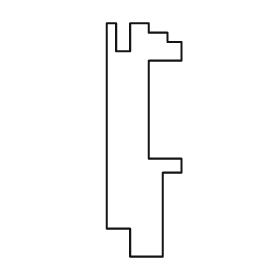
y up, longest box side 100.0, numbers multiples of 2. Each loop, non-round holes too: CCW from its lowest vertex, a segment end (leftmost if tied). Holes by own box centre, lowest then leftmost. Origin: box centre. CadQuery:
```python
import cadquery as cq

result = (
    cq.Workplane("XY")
    .moveTo(-6.0, -50.0)
    .lineTo(8.0, -50.0)
    .lineTo(8.0, -14.0)
    .lineTo(16.0, -14.0)
    .lineTo(16.0, -8.0)
    .lineTo(2.0, -8.0)
    .lineTo(2.0, 34.0)
    .lineTo(16.0, 34.0)
    .lineTo(16.0, 42.0)
    .lineTo(10.0, 42.0)
    .lineTo(10.0, 46.0)
    .lineTo(2.0, 46.0)
    .lineTo(2.0, 50.0)
    .lineTo(-6.0, 50.0)
    .lineTo(-6.0, 38.0)
    .lineTo(-12.0, 38.0)
    .lineTo(-12.0, 50.0)
    .lineTo(-16.0, 50.0)
    .lineTo(-16.0, -38.0)
    .lineTo(-6.0, -38.0)
    .close()
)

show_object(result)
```